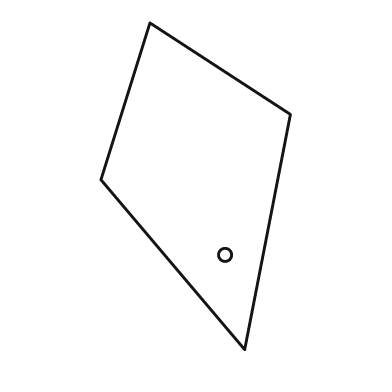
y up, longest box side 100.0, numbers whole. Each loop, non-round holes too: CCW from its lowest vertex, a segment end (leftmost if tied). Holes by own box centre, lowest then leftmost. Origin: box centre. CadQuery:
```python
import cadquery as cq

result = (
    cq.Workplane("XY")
    .moveTo(15.0, -50.0)
    .lineTo(29.0, 22.0)
    .lineTo(-14.0, 50.0)
    .lineTo(-29.0, 2.0)
    .close()
    .moveTo(9.0, -21.0)
    .circle(2.0)
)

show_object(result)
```